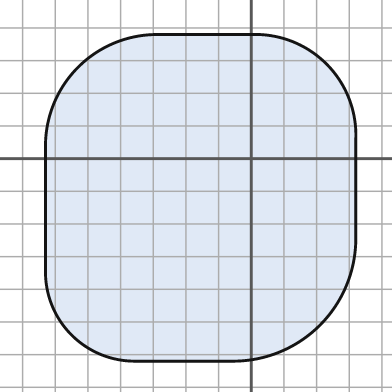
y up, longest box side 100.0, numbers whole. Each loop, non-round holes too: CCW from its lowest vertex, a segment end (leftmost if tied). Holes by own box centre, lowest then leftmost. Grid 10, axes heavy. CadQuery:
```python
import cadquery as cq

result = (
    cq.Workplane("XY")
    .moveTo(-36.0, -62.0)
    .lineTo(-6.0, -62.0)
    .threePointArc((21.0, -51.0), (32.0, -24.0))
    .lineTo(32.0, 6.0)
    .threePointArc((23.0, 29.0), (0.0, 38.0))
    .lineTo(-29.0, 38.0)
    .threePointArc((-53.0, 28.0), (-63.0, 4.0))
    .lineTo(-63.0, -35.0)
    .threePointArc((-55.0, -54.0), (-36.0, -62.0))
    .close()
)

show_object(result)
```